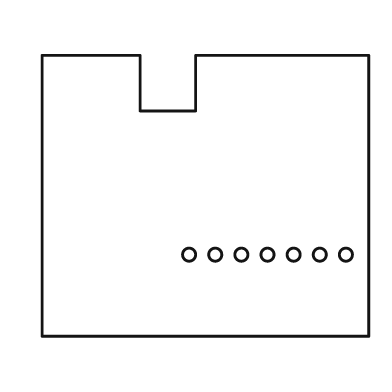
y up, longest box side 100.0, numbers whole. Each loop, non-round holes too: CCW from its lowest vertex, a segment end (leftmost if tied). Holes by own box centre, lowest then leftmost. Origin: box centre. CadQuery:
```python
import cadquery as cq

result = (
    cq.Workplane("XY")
    .moveTo(-50.0, -43.0)
    .lineTo(50.0, -43.0)
    .lineTo(50.0, 43.0)
    .lineTo(-3.0, 43.0)
    .lineTo(-3.0, 26.0)
    .lineTo(-20.0, 26.0)
    .lineTo(-20.0, 43.0)
    .lineTo(-50.0, 43.0)
    .close()
    .moveTo(-5.0, -18.0)
    .circle(2.0)
    .moveTo(3.0, -18.0)
    .circle(2.0)
    .moveTo(11.0, -18.0)
    .circle(2.0)
    .moveTo(19.0, -18.0)
    .circle(2.0)
    .moveTo(27.0, -18.0)
    .circle(2.0)
    .moveTo(35.0, -18.0)
    .circle(2.0)
    .moveTo(43.0, -18.0)
    .circle(2.0)
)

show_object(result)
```